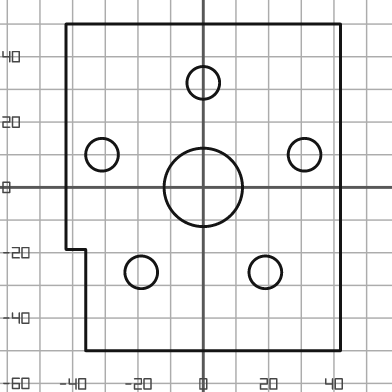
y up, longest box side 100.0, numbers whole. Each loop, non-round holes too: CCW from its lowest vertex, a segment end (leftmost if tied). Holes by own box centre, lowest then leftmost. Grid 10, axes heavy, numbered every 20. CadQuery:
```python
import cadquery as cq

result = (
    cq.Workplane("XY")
    .moveTo(-36.0, -50.0)
    .lineTo(42.0, -50.0)
    .lineTo(42.0, 50.0)
    .lineTo(-42.0, 50.0)
    .lineTo(-42.0, -19.0)
    .lineTo(-36.0, -19.0)
    .close()
    .moveTo(-19.0, -26.0)
    .circle(5.0)
    .moveTo(19.0, -26.0)
    .circle(5.0)
    .moveTo(0.0, 0.0)
    .circle(12.0)
    .moveTo(-31.0, 10.0)
    .circle(5.0)
    .moveTo(31.0, 10.0)
    .circle(5.0)
    .moveTo(0.0, 32.0)
    .circle(5.0)
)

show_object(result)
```